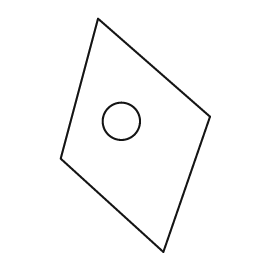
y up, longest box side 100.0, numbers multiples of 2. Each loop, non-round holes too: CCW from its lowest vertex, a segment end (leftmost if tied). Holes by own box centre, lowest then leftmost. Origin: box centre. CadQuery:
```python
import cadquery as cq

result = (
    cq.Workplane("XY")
    .moveTo(12.0, -50.0)
    .lineTo(32.0, 8.0)
    .lineTo(-16.0, 50.0)
    .lineTo(-32.0, -10.0)
    .close()
    .moveTo(-6.0, 6.0)
    .circle(8.0)
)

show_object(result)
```